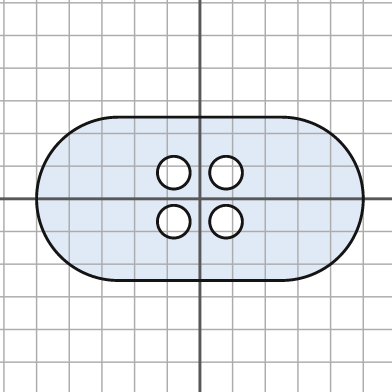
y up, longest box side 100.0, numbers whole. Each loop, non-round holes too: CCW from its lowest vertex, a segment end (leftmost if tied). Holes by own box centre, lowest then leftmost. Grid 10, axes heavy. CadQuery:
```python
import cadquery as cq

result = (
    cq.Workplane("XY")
    .moveTo(-25.0, -25.0)
    .lineTo(25.0, -25.0)
    .threePointArc((50.0, 0.0), (25.0, 25.0))
    .lineTo(-25.0, 25.0)
    .threePointArc((-50.0, 0.0), (-25.0, -25.0))
    .close()
    .moveTo(-8.0, -7.0)
    .circle(5.0)
    .moveTo(8.0, -7.0)
    .circle(5.0)
    .moveTo(-8.0, 8.0)
    .circle(5.0)
    .moveTo(8.0, 8.0)
    .circle(5.0)
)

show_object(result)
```